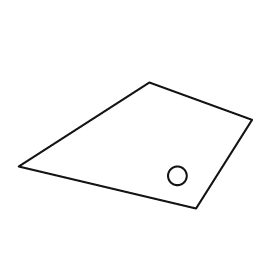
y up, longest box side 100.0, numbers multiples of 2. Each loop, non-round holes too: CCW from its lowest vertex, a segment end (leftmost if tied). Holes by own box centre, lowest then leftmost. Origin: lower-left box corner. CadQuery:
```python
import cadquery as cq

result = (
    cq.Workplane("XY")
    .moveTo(76.0, 0.0)
    .lineTo(100.0, 38.0)
    .lineTo(56.0, 54.0)
    .lineTo(0.0, 18.0)
    .close()
    .moveTo(68.0, 14.0)
    .circle(4.0)
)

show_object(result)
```